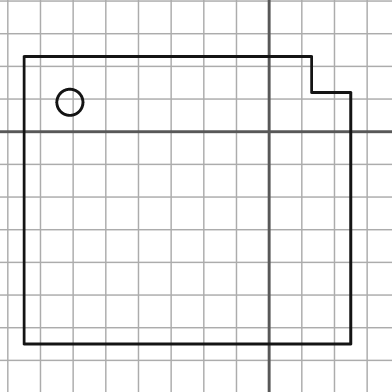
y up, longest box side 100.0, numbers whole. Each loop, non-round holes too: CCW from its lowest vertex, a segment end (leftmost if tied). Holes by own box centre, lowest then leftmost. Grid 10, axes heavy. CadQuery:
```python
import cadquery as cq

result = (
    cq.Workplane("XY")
    .moveTo(-75.0, -65.0)
    .lineTo(25.0, -65.0)
    .lineTo(25.0, 12.0)
    .lineTo(13.0, 12.0)
    .lineTo(13.0, 23.0)
    .lineTo(-75.0, 23.0)
    .close()
    .moveTo(-61.0, 9.0)
    .circle(4.0)
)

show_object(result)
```